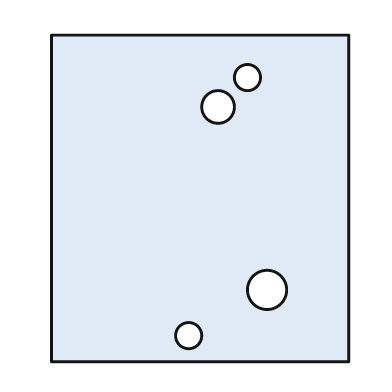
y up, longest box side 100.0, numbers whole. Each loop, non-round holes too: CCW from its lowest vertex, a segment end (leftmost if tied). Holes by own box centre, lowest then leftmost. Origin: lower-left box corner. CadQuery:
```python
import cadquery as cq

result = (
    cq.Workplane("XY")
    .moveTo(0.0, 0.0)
    .lineTo(91.0, 0.0)
    .lineTo(91.0, 100.0)
    .lineTo(0.0, 100.0)
    .close()
    .moveTo(42.0, 8.0)
    .circle(4.0)
    .moveTo(66.0, 22.0)
    .circle(6.0)
    .moveTo(51.0, 78.0)
    .circle(5.0)
    .moveTo(60.0, 87.0)
    .circle(4.0)
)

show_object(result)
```